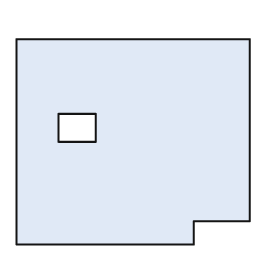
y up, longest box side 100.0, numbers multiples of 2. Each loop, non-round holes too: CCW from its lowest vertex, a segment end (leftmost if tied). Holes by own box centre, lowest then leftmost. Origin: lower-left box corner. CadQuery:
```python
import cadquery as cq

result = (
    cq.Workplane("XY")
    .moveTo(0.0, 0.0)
    .lineTo(76.0, 0.0)
    .lineTo(76.0, 10.0)
    .lineTo(100.0, 10.0)
    .lineTo(100.0, 88.0)
    .lineTo(0.0, 88.0)
    .close()
    .moveTo(18.0, 44.0)
    .lineTo(34.0, 44.0)
    .lineTo(34.0, 56.0)
    .lineTo(18.0, 56.0)
    .close()
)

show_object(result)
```